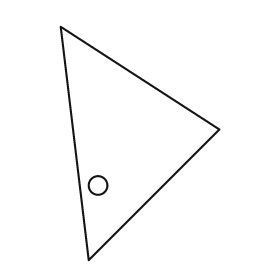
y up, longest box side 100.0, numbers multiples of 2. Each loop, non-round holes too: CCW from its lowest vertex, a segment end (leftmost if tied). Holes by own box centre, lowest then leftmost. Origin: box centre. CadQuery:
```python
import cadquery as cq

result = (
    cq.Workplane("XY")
    .moveTo(-22.0, -50.0)
    .lineTo(34.0, 6.0)
    .lineTo(-34.0, 50.0)
    .close()
    .moveTo(-18.0, -18.0)
    .circle(4.0)
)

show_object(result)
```